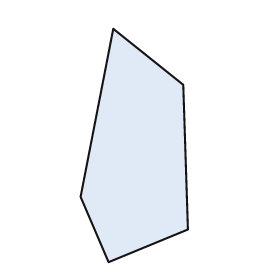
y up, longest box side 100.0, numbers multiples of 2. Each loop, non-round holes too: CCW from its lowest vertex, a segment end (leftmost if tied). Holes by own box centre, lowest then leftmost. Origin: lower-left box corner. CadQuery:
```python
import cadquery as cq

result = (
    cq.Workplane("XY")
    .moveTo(12.0, 0.0)
    .lineTo(46.0, 14.0)
    .lineTo(44.0, 76.0)
    .lineTo(14.0, 100.0)
    .lineTo(0.0, 28.0)
    .close()
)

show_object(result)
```